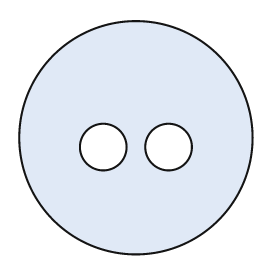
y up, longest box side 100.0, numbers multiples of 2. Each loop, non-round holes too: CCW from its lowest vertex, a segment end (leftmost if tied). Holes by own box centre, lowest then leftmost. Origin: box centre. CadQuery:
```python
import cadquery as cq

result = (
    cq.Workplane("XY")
    .moveTo(0.0, 0.0)
    .circle(50.0)
    .moveTo(-14.0, -4.0)
    .circle(10.0)
    .moveTo(14.0, -4.0)
    .circle(10.0)
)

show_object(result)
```